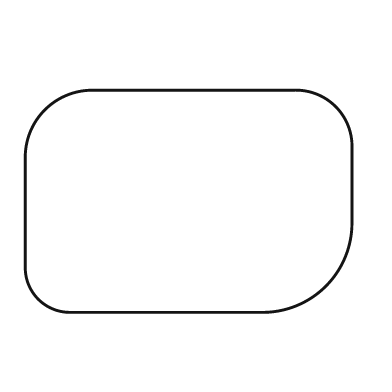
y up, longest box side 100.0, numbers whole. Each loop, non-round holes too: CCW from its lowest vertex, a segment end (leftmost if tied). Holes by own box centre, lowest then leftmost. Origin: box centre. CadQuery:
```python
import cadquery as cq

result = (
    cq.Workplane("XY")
    .moveTo(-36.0, -34.0)
    .lineTo(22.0, -34.0)
    .threePointArc((42.0, -26.0), (50.0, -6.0))
    .lineTo(50.0, 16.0)
    .threePointArc((45.0, 29.0), (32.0, 34.0))
    .lineTo(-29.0, 34.0)
    .threePointArc((-44.0, 28.0), (-50.0, 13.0))
    .lineTo(-50.0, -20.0)
    .threePointArc((-46.0, -30.0), (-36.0, -34.0))
    .close()
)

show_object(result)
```